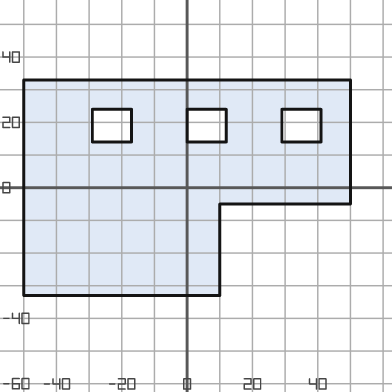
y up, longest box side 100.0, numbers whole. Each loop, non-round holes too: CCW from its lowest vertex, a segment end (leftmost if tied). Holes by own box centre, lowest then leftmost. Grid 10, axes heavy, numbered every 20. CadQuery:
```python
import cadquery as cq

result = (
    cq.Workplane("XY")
    .moveTo(-50.0, -33.0)
    .lineTo(10.0, -33.0)
    .lineTo(10.0, -5.0)
    .lineTo(50.0, -5.0)
    .lineTo(50.0, 33.0)
    .lineTo(-50.0, 33.0)
    .close()
    .moveTo(-29.0, 14.0)
    .lineTo(-17.0, 14.0)
    .lineTo(-17.0, 24.0)
    .lineTo(-29.0, 24.0)
    .close()
    .moveTo(0.0, 14.0)
    .lineTo(12.0, 14.0)
    .lineTo(12.0, 24.0)
    .lineTo(0.0, 24.0)
    .close()
    .moveTo(29.0, 14.0)
    .lineTo(41.0, 14.0)
    .lineTo(41.0, 24.0)
    .lineTo(29.0, 24.0)
    .close()
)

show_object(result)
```